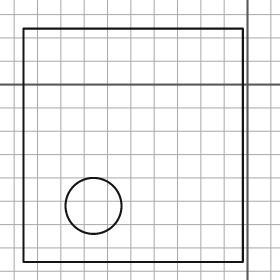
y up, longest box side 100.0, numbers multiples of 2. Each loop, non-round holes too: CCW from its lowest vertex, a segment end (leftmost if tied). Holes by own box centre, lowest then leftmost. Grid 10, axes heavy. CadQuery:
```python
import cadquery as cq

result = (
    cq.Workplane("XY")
    .moveTo(-96.0, -76.0)
    .lineTo(-2.0, -76.0)
    .lineTo(-2.0, 24.0)
    .lineTo(-96.0, 24.0)
    .close()
    .moveTo(-66.0, -52.0)
    .circle(12.0)
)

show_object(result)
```